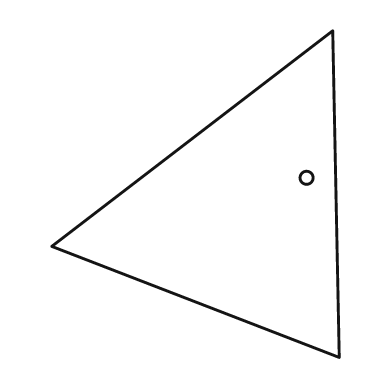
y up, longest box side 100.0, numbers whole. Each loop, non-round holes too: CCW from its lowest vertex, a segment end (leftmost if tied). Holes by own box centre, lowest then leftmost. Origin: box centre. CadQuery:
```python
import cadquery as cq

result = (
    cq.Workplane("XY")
    .moveTo(44.0, -50.0)
    .lineTo(42.0, 50.0)
    .lineTo(-44.0, -16.0)
    .close()
    .moveTo(34.0, 5.0)
    .circle(2.0)
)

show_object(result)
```